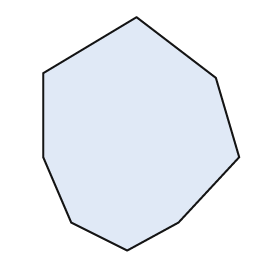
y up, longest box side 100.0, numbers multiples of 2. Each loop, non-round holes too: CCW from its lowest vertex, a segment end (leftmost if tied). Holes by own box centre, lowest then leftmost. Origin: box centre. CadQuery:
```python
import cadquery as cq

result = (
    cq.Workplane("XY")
    .moveTo(-6.0, -50.0)
    .lineTo(16.0, -38.0)
    .lineTo(42.0, -10.0)
    .lineTo(32.0, 24.0)
    .lineTo(-2.0, 50.0)
    .lineTo(-42.0, 26.0)
    .lineTo(-42.0, -10.0)
    .lineTo(-30.0, -38.0)
    .close()
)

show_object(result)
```